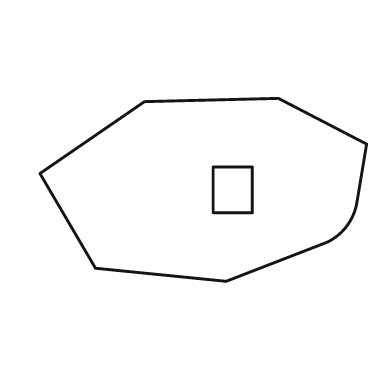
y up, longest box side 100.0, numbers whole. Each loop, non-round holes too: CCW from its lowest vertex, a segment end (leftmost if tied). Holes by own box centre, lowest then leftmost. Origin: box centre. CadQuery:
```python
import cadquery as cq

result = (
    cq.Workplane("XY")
    .moveTo(7.0, -28.0)
    .lineTo(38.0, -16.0)
    .threePointArc((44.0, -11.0), (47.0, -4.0))
    .lineTo(50.0, 14.0)
    .lineTo(23.0, 28.0)
    .lineTo(-18.0, 27.0)
    .lineTo(-50.0, 5.0)
    .lineTo(-33.0, -24.0)
    .close()
    .moveTo(3.0, -7.0)
    .lineTo(15.0, -7.0)
    .lineTo(15.0, 7.0)
    .lineTo(3.0, 7.0)
    .close()
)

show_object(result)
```